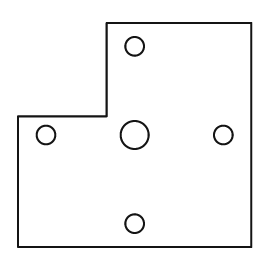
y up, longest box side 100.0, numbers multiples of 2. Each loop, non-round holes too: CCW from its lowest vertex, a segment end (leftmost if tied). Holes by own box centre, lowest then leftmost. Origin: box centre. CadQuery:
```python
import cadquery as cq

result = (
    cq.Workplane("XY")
    .moveTo(-50.0, -48.0)
    .lineTo(50.0, -48.0)
    .lineTo(50.0, 48.0)
    .lineTo(-12.0, 48.0)
    .lineTo(-12.0, 8.0)
    .lineTo(-50.0, 8.0)
    .close()
    .moveTo(0.0, -38.0)
    .circle(4.0)
    .moveTo(-38.0, 0.0)
    .circle(4.0)
    .moveTo(0.0, 0.0)
    .circle(6.0)
    .moveTo(38.0, 0.0)
    .circle(4.0)
    .moveTo(0.0, 38.0)
    .circle(4.0)
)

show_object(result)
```